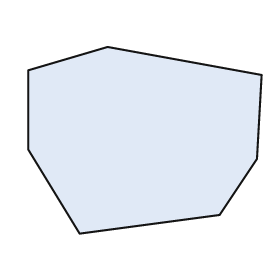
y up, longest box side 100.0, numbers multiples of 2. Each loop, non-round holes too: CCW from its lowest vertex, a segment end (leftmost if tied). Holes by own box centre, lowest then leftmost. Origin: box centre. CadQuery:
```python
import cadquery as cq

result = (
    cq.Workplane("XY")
    .moveTo(-28.0, -40.0)
    .lineTo(32.0, -32.0)
    .lineTo(48.0, -8.0)
    .lineTo(50.0, 28.0)
    .lineTo(-16.0, 40.0)
    .lineTo(-50.0, 30.0)
    .lineTo(-50.0, -4.0)
    .close()
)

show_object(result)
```